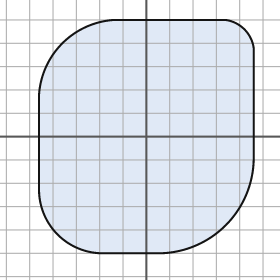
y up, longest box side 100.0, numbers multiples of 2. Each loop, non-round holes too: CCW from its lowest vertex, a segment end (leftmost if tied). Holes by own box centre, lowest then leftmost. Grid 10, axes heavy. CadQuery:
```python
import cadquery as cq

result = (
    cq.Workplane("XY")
    .moveTo(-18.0, -50.0)
    .lineTo(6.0, -50.0)
    .threePointArc((34.0, -38.0), (46.0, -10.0))
    .lineTo(46.0, 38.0)
    .threePointArc((42.0, 46.0), (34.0, 50.0))
    .lineTo(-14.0, 50.0)
    .threePointArc((-36.0, 40.0), (-46.0, 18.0))
    .lineTo(-46.0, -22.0)
    .threePointArc((-38.0, -42.0), (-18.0, -50.0))
    .close()
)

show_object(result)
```